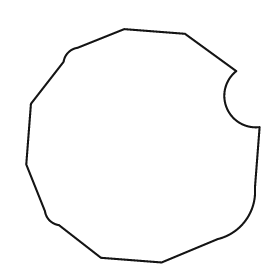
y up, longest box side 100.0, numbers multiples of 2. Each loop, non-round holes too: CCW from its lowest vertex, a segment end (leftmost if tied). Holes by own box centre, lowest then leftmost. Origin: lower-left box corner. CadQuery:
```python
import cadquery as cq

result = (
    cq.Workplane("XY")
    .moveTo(58.0, 0.0)
    .lineTo(82.0, 10.0)
    .threePointArc((94.0, 18.0), (98.0, 32.0))
    .lineTo(100.0, 58.0)
    .threePointArc((86.0, 66.0), (90.0, 82.0))
    .lineTo(68.0, 98.0)
    .lineTo(42.0, 100.0)
    .lineTo(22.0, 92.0)
    .threePointArc((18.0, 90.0), (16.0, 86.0))
    .lineTo(2.0, 68.0)
    .lineTo(0.0, 42.0)
    .lineTo(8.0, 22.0)
    .threePointArc((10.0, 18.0), (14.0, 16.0))
    .lineTo(32.0, 2.0)
    .close()
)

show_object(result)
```